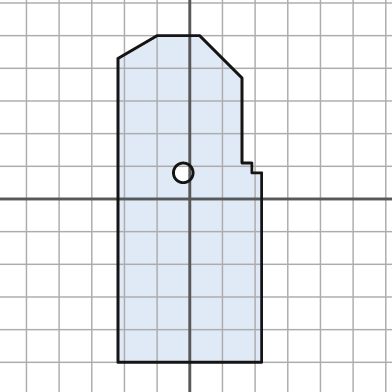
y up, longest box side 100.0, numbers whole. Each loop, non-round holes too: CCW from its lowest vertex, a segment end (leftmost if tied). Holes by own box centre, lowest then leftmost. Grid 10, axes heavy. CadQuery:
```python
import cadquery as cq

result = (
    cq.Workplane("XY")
    .moveTo(-22.0, -50.0)
    .lineTo(22.0, -50.0)
    .lineTo(22.0, 8.0)
    .lineTo(19.0, 8.0)
    .lineTo(19.0, 11.0)
    .lineTo(16.0, 11.0)
    .lineTo(16.0, 37.0)
    .lineTo(3.0, 50.0)
    .lineTo(-10.0, 50.0)
    .lineTo(-22.0, 43.0)
    .close()
    .moveTo(-2.0, 8.0)
    .circle(3.0)
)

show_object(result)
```